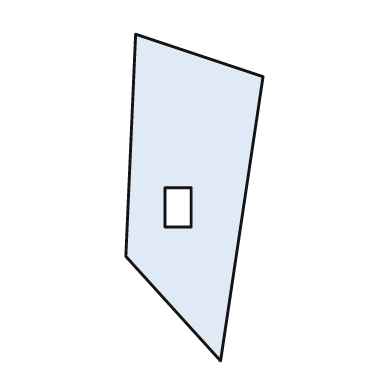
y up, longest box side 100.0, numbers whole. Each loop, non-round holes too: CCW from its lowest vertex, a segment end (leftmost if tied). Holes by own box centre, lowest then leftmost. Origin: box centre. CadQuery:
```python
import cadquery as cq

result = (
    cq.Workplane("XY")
    .moveTo(8.0, -50.0)
    .lineTo(21.0, 37.0)
    .lineTo(-18.0, 50.0)
    .lineTo(-21.0, -18.0)
    .close()
    .moveTo(-9.0, -9.0)
    .lineTo(-1.0, -9.0)
    .lineTo(-1.0, 3.0)
    .lineTo(-9.0, 3.0)
    .close()
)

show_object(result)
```